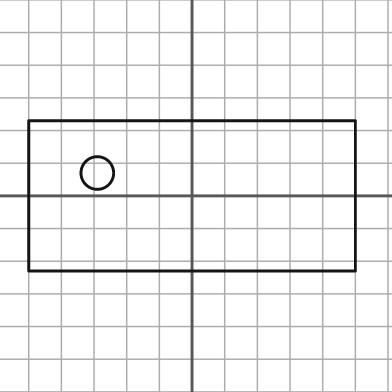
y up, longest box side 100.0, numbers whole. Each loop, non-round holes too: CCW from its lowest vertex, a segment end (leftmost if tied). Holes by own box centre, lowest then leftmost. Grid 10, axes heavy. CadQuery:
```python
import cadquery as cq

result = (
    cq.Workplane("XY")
    .moveTo(-50.0, -23.0)
    .lineTo(50.0, -23.0)
    .lineTo(50.0, 23.0)
    .lineTo(-50.0, 23.0)
    .close()
    .moveTo(-29.0, 7.0)
    .circle(5.0)
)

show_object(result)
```